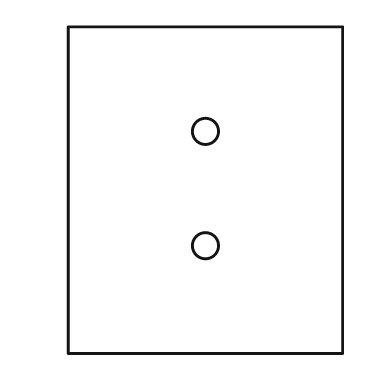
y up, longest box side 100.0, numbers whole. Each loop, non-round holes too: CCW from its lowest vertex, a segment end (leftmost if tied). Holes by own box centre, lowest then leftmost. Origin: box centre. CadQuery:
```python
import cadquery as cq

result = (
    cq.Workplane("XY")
    .moveTo(-42.0, -50.0)
    .lineTo(42.0, -50.0)
    .lineTo(42.0, 50.0)
    .lineTo(-42.0, 50.0)
    .close()
    .moveTo(0.0, -17.0)
    .circle(4.0)
    .moveTo(0.0, 18.0)
    .circle(4.0)
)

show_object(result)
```